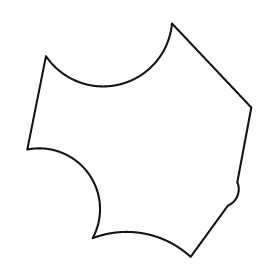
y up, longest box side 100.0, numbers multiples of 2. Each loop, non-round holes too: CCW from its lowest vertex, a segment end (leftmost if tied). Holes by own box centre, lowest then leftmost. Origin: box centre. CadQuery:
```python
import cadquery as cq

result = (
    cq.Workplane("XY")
    .moveTo(22.0, -50.0)
    .lineTo(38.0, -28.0)
    .threePointArc((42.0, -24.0), (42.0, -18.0))
    .lineTo(48.0, 14.0)
    .lineTo(14.0, 50.0)
    .threePointArc((-8.0, 24.0), (-40.0, 36.0))
    .lineTo(-48.0, -4.0)
    .threePointArc((-22.0, -14.0), (-20.0, -42.0))
    .threePointArc((2.0, -40.0), (22.0, -50.0))
    .close()
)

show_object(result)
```